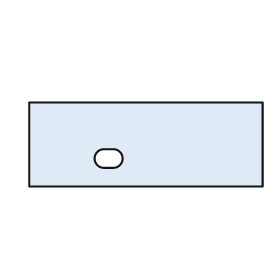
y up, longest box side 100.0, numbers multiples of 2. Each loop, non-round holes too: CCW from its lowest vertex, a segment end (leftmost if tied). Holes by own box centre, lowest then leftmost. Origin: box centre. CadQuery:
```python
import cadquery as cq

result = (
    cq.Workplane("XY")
    .moveTo(-50.0, -18.0)
    .lineTo(50.0, -18.0)
    .lineTo(50.0, 18.0)
    .lineTo(-50.0, 18.0)
    .close()
    .moveTo(-18.0, -10.0)
    .lineTo(-14.0, -10.0)
    .threePointArc((-10.0, -6.0), (-14.0, -2.0))
    .lineTo(-18.0, -2.0)
    .threePointArc((-22.0, -6.0), (-18.0, -10.0))
    .close()
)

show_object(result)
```